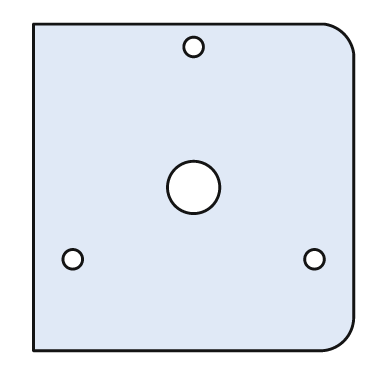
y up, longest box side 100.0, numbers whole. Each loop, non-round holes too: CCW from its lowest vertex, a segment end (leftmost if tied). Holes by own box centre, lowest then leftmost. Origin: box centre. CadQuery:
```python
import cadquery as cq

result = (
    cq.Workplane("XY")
    .moveTo(-49.0, -50.0)
    .lineTo(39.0, -50.0)
    .threePointArc((46.0, -47.0), (49.0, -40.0))
    .lineTo(49.0, 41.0)
    .threePointArc((46.0, 47.0), (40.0, 50.0))
    .lineTo(-49.0, 50.0)
    .close()
    .moveTo(-37.0, -22.0)
    .circle(3.0)
    .moveTo(37.0, -22.0)
    .circle(3.0)
    .moveTo(0.0, 0.0)
    .circle(8.0)
    .moveTo(0.0, 43.0)
    .circle(3.0)
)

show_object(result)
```